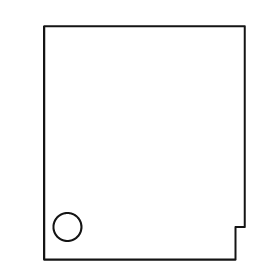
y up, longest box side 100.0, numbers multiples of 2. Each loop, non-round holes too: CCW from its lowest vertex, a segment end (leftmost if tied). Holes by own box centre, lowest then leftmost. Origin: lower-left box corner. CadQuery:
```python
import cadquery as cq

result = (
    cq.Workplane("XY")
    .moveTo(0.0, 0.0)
    .lineTo(82.0, 0.0)
    .lineTo(82.0, 14.0)
    .lineTo(86.0, 14.0)
    .lineTo(86.0, 100.0)
    .lineTo(0.0, 100.0)
    .close()
    .moveTo(10.0, 14.0)
    .circle(6.0)
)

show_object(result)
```